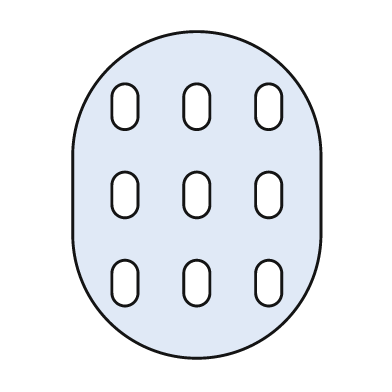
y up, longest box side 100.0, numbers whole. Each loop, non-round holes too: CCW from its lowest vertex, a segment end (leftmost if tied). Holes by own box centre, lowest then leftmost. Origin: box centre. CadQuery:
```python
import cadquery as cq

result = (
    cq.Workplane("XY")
    .moveTo(-38.0, -12.0)
    .threePointArc((0.0, -50.0), (38.0, -12.0))
    .lineTo(38.0, 12.0)
    .threePointArc((0.0, 50.0), (-38.0, 12.0))
    .close()
    .moveTo(-26.0, -30.0)
    .threePointArc((-22.0, -34.0), (-18.0, -30.0))
    .lineTo(-18.0, -24.0)
    .threePointArc((-22.0, -20.0), (-26.0, -24.0))
    .close()
    .moveTo(-4.0, -30.0)
    .threePointArc((0.0, -34.0), (4.0, -30.0))
    .lineTo(4.0, -24.0)
    .threePointArc((0.0, -20.0), (-4.0, -24.0))
    .close()
    .moveTo(18.0, -30.0)
    .threePointArc((22.0, -34.0), (26.0, -30.0))
    .lineTo(26.0, -24.0)
    .threePointArc((22.0, -20.0), (18.0, -24.0))
    .close()
    .moveTo(-26.0, -3.0)
    .threePointArc((-22.0, -7.0), (-18.0, -3.0))
    .lineTo(-18.0, 3.0)
    .threePointArc((-22.0, 7.0), (-26.0, 3.0))
    .close()
    .moveTo(-4.0, -3.0)
    .threePointArc((0.0, -7.0), (4.0, -3.0))
    .lineTo(4.0, 3.0)
    .threePointArc((0.0, 7.0), (-4.0, 3.0))
    .close()
    .moveTo(18.0, -3.0)
    .threePointArc((22.0, -7.0), (26.0, -3.0))
    .lineTo(26.0, 3.0)
    .threePointArc((22.0, 7.0), (18.0, 3.0))
    .close()
    .moveTo(-26.0, 24.0)
    .threePointArc((-22.0, 20.0), (-18.0, 24.0))
    .lineTo(-18.0, 30.0)
    .threePointArc((-22.0, 34.0), (-26.0, 30.0))
    .close()
    .moveTo(-4.0, 24.0)
    .threePointArc((0.0, 20.0), (4.0, 24.0))
    .lineTo(4.0, 30.0)
    .threePointArc((0.0, 34.0), (-4.0, 30.0))
    .close()
    .moveTo(18.0, 24.0)
    .threePointArc((22.0, 20.0), (26.0, 24.0))
    .lineTo(26.0, 30.0)
    .threePointArc((22.0, 34.0), (18.0, 30.0))
    .close()
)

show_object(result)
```